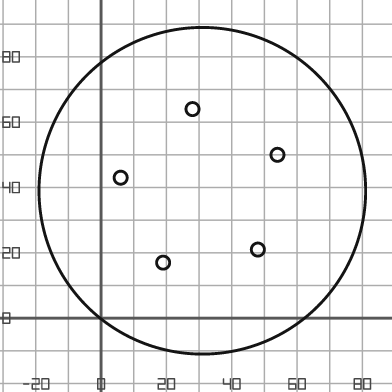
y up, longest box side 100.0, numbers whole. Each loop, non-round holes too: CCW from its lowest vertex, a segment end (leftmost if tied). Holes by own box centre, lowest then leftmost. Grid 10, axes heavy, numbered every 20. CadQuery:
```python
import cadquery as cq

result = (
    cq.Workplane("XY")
    .moveTo(31.0, 39.0)
    .circle(50.0)
    .moveTo(19.0, 17.0)
    .circle(2.0)
    .moveTo(48.0, 21.0)
    .circle(2.0)
    .moveTo(6.0, 43.0)
    .circle(2.0)
    .moveTo(54.0, 50.0)
    .circle(2.0)
    .moveTo(28.0, 64.0)
    .circle(2.0)
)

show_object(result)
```